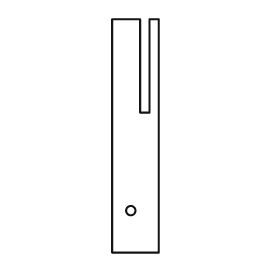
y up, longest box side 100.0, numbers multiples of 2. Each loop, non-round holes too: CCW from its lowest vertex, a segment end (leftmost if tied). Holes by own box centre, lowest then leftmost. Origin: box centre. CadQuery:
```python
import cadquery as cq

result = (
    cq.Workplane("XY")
    .moveTo(-10.0, -50.0)
    .lineTo(10.0, -50.0)
    .lineTo(10.0, 50.0)
    .lineTo(6.0, 50.0)
    .lineTo(6.0, 10.0)
    .lineTo(2.0, 10.0)
    .lineTo(2.0, 50.0)
    .lineTo(-10.0, 50.0)
    .close()
    .moveTo(-2.0, -32.0)
    .circle(2.0)
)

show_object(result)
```